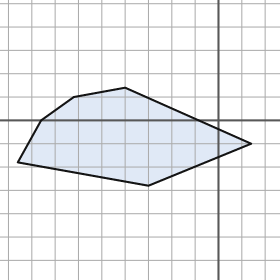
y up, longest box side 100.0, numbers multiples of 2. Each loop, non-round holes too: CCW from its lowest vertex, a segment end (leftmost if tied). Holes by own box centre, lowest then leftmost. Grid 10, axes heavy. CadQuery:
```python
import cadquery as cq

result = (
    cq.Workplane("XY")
    .moveTo(-30.0, -28.0)
    .lineTo(14.0, -10.0)
    .lineTo(-40.0, 14.0)
    .lineTo(-62.0, 10.0)
    .lineTo(-76.0, 0.0)
    .lineTo(-86.0, -18.0)
    .close()
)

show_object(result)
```